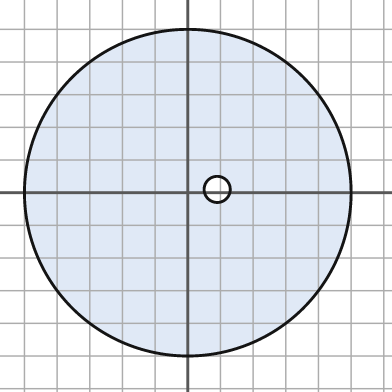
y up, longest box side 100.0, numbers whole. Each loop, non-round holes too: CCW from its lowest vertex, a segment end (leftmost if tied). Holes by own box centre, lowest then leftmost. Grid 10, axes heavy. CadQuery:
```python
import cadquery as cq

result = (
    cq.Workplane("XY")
    .moveTo(0.0, 0.0)
    .circle(50.0)
    .moveTo(9.0, 1.0)
    .circle(4.0)
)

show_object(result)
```